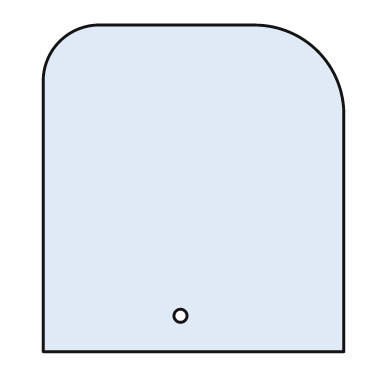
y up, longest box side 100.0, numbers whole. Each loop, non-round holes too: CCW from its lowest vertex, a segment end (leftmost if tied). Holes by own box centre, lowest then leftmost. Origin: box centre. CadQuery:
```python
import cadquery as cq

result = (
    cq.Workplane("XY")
    .moveTo(-46.0, -50.0)
    .lineTo(46.0, -50.0)
    .lineTo(46.0, 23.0)
    .threePointArc((38.0, 42.0), (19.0, 50.0))
    .lineTo(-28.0, 50.0)
    .threePointArc((-41.0, 45.0), (-46.0, 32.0))
    .close()
    .moveTo(-4.0, -39.0)
    .circle(2.0)
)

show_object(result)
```